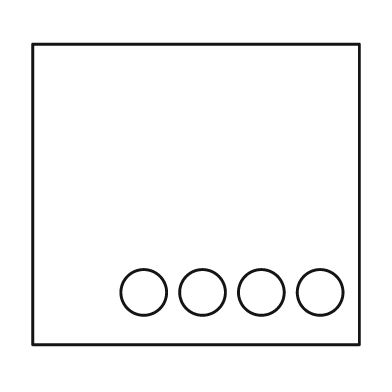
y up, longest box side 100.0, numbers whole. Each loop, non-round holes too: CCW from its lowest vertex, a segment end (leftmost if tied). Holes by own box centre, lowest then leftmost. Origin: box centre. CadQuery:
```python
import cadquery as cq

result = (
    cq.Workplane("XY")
    .moveTo(-50.0, -46.0)
    .lineTo(50.0, -46.0)
    .lineTo(50.0, 46.0)
    .lineTo(-50.0, 46.0)
    .close()
    .moveTo(-16.0, -30.0)
    .circle(7.0)
    .moveTo(2.0, -30.0)
    .circle(7.0)
    .moveTo(20.0, -30.0)
    .circle(7.0)
    .moveTo(38.0, -30.0)
    .circle(7.0)
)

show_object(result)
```